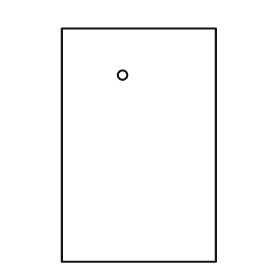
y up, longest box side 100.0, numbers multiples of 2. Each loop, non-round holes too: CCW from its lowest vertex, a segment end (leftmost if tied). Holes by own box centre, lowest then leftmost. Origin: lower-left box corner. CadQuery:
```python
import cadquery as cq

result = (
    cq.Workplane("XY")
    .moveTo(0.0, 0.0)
    .lineTo(66.0, 0.0)
    .lineTo(66.0, 100.0)
    .lineTo(0.0, 100.0)
    .close()
    .moveTo(26.0, 80.0)
    .circle(2.0)
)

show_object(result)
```